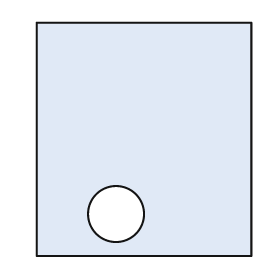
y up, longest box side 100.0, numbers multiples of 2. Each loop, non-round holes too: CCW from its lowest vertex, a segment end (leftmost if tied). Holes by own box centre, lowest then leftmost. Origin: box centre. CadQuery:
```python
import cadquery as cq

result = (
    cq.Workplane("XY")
    .moveTo(-46.0, -50.0)
    .lineTo(46.0, -50.0)
    .lineTo(46.0, 50.0)
    .lineTo(-46.0, 50.0)
    .close()
    .moveTo(-12.0, -32.0)
    .circle(12.0)
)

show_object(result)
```